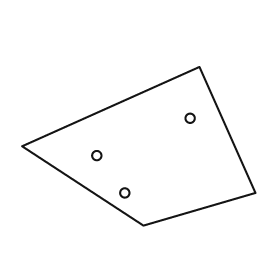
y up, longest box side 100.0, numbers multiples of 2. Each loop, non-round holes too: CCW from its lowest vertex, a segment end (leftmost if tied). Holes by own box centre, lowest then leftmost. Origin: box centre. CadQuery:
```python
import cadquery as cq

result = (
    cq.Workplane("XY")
    .moveTo(2.0, -34.0)
    .lineTo(50.0, -20.0)
    .lineTo(26.0, 34.0)
    .lineTo(-50.0, 0.0)
    .close()
    .moveTo(-6.0, -20.0)
    .circle(2.0)
    .moveTo(-18.0, -4.0)
    .circle(2.0)
    .moveTo(22.0, 12.0)
    .circle(2.0)
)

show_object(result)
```